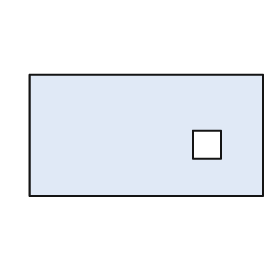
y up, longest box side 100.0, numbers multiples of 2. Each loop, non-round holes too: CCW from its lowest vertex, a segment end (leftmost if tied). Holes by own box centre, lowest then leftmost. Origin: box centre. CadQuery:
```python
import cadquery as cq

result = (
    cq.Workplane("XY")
    .moveTo(-50.0, -26.0)
    .lineTo(50.0, -26.0)
    .lineTo(50.0, 26.0)
    .lineTo(-50.0, 26.0)
    .close()
    .moveTo(20.0, -10.0)
    .lineTo(32.0, -10.0)
    .lineTo(32.0, 2.0)
    .lineTo(20.0, 2.0)
    .close()
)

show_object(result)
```